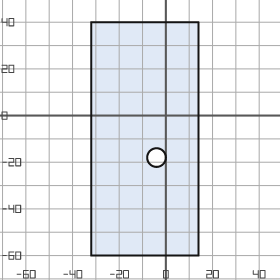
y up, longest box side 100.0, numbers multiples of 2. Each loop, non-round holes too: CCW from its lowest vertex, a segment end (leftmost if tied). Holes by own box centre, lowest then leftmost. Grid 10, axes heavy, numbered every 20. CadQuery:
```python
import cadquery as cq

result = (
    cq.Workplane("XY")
    .moveTo(-32.0, -60.0)
    .lineTo(14.0, -60.0)
    .lineTo(14.0, 40.0)
    .lineTo(-32.0, 40.0)
    .close()
    .moveTo(-4.0, -18.0)
    .circle(4.0)
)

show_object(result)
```